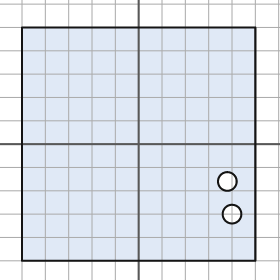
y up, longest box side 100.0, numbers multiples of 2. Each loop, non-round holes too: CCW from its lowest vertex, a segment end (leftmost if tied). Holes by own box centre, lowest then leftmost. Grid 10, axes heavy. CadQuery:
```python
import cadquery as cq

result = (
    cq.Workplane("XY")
    .moveTo(-50.0, -50.0)
    .lineTo(50.0, -50.0)
    .lineTo(50.0, 50.0)
    .lineTo(-50.0, 50.0)
    .close()
    .moveTo(40.0, -30.0)
    .circle(4.0)
    .moveTo(38.0, -16.0)
    .circle(4.0)
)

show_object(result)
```